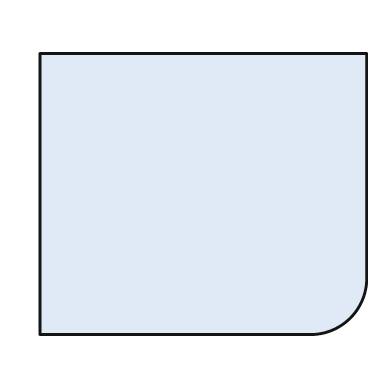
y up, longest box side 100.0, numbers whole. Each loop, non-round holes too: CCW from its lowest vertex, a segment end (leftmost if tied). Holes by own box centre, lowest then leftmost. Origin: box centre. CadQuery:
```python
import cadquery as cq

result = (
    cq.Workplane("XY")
    .moveTo(-50.0, -43.0)
    .lineTo(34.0, -43.0)
    .threePointArc((45.0, -38.0), (50.0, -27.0))
    .lineTo(50.0, 43.0)
    .lineTo(-50.0, 43.0)
    .close()
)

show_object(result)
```